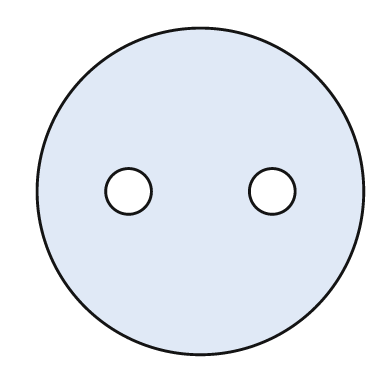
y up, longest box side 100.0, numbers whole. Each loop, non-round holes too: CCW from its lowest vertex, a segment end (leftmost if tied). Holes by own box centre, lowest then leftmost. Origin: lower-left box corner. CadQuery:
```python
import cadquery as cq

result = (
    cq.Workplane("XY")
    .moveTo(50.0, 50.0)
    .circle(50.0)
    .moveTo(28.0, 50.0)
    .circle(7.0)
    .moveTo(72.0, 50.0)
    .circle(7.0)
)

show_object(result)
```